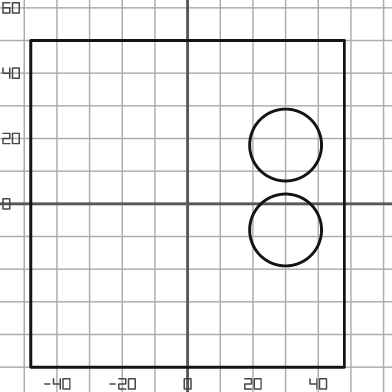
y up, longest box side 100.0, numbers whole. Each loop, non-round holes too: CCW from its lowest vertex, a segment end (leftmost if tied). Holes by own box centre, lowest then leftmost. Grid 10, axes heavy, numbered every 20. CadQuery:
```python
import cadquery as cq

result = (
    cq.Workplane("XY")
    .moveTo(-48.0, -50.0)
    .lineTo(48.0, -50.0)
    .lineTo(48.0, 50.0)
    .lineTo(-48.0, 50.0)
    .close()
    .moveTo(30.0, -8.0)
    .circle(11.0)
    .moveTo(30.0, 18.0)
    .circle(11.0)
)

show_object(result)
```